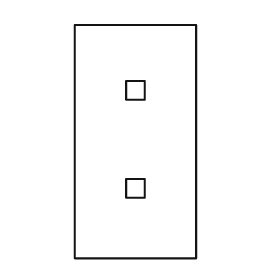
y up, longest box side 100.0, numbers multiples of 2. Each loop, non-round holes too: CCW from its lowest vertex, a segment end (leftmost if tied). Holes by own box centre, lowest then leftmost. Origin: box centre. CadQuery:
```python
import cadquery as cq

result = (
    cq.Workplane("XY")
    .moveTo(-26.0, -50.0)
    .lineTo(26.0, -50.0)
    .lineTo(26.0, 50.0)
    .lineTo(-26.0, 50.0)
    .close()
    .moveTo(-4.0, -24.0)
    .lineTo(4.0, -24.0)
    .lineTo(4.0, -16.0)
    .lineTo(-4.0, -16.0)
    .close()
    .moveTo(-4.0, 18.0)
    .lineTo(4.0, 18.0)
    .lineTo(4.0, 26.0)
    .lineTo(-4.0, 26.0)
    .close()
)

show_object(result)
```